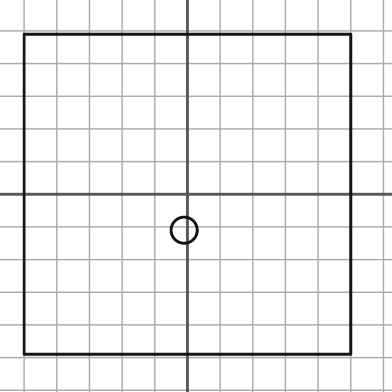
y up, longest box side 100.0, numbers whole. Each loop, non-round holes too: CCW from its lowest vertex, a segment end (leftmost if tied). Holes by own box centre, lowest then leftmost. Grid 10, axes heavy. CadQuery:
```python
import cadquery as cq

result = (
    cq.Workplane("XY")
    .moveTo(-50.0, -49.0)
    .lineTo(50.0, -49.0)
    .lineTo(50.0, 49.0)
    .lineTo(-50.0, 49.0)
    .close()
    .moveTo(-1.0, -11.0)
    .circle(4.0)
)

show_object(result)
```